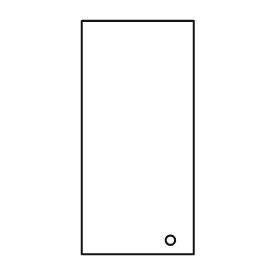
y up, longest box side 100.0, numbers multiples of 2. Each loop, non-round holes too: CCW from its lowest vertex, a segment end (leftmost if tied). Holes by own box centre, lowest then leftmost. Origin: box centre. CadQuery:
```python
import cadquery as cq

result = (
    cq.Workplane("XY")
    .moveTo(-24.0, -50.0)
    .lineTo(24.0, -50.0)
    .lineTo(24.0, 50.0)
    .lineTo(-24.0, 50.0)
    .close()
    .moveTo(14.0, -44.0)
    .circle(2.0)
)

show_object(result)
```